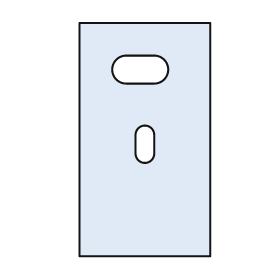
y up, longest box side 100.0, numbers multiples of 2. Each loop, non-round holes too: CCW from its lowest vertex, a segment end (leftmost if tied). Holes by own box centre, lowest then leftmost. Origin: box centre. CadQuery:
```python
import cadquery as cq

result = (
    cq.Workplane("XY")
    .moveTo(-28.0, -50.0)
    .lineTo(28.0, -50.0)
    .lineTo(28.0, 50.0)
    .lineTo(-28.0, 50.0)
    .close()
    .moveTo(-4.0, -6.0)
    .threePointArc((0.0, -10.0), (4.0, -6.0))
    .lineTo(4.0, 2.0)
    .threePointArc((0.0, 6.0), (-4.0, 2.0))
    .close()
    .moveTo(-8.0, 24.0)
    .lineTo(4.0, 24.0)
    .threePointArc((10.0, 30.0), (4.0, 36.0))
    .lineTo(-8.0, 36.0)
    .threePointArc((-14.0, 30.0), (-8.0, 24.0))
    .close()
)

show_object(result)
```